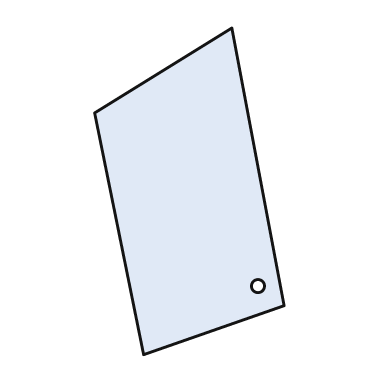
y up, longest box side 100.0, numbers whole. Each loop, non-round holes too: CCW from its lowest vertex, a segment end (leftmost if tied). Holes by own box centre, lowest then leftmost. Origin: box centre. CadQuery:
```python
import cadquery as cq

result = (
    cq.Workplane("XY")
    .moveTo(-14.0, -50.0)
    .lineTo(29.0, -35.0)
    .lineTo(13.0, 50.0)
    .lineTo(-29.0, 24.0)
    .close()
    .moveTo(21.0, -29.0)
    .circle(2.0)
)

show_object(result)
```